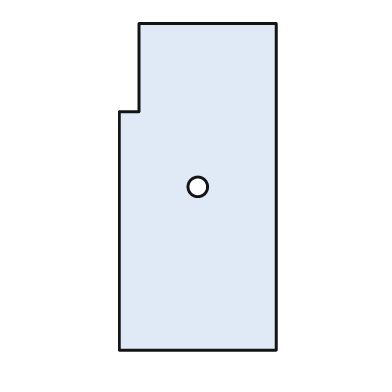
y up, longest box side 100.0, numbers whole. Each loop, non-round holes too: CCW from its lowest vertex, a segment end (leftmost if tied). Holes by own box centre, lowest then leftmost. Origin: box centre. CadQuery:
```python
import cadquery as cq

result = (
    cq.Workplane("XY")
    .moveTo(-24.0, -50.0)
    .lineTo(24.0, -50.0)
    .lineTo(24.0, 50.0)
    .lineTo(-18.0, 50.0)
    .lineTo(-18.0, 23.0)
    .lineTo(-24.0, 23.0)
    .close()
    .moveTo(0.0, 0.0)
    .circle(3.0)
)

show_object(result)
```